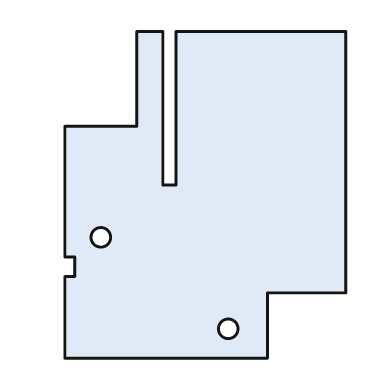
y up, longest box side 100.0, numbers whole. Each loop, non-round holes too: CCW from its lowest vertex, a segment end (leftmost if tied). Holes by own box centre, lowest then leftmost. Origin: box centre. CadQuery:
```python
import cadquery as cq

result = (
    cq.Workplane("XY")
    .moveTo(-43.0, -50.0)
    .lineTo(19.0, -50.0)
    .lineTo(19.0, -30.0)
    .lineTo(43.0, -30.0)
    .lineTo(43.0, 50.0)
    .lineTo(-9.0, 50.0)
    .lineTo(-9.0, 3.0)
    .lineTo(-13.0, 3.0)
    .lineTo(-13.0, 50.0)
    .lineTo(-21.0, 50.0)
    .lineTo(-21.0, 21.0)
    .lineTo(-43.0, 21.0)
    .lineTo(-43.0, -19.0)
    .lineTo(-40.0, -19.0)
    .lineTo(-40.0, -25.0)
    .lineTo(-43.0, -25.0)
    .close()
    .moveTo(7.0, -41.0)
    .circle(3.0)
    .moveTo(-32.0, -13.0)
    .circle(3.0)
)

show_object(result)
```